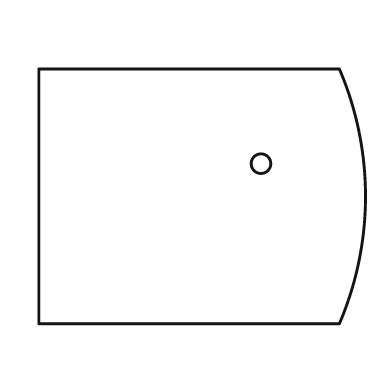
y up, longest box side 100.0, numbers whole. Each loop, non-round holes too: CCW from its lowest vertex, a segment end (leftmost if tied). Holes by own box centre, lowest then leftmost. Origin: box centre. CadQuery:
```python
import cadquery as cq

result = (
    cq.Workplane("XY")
    .moveTo(-50.0, -39.0)
    .lineTo(42.0, -39.0)
    .threePointArc((50.0, 0.0), (42.0, 39.0))
    .lineTo(-50.0, 39.0)
    .close()
    .moveTo(18.0, 10.0)
    .circle(3.0)
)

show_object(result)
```